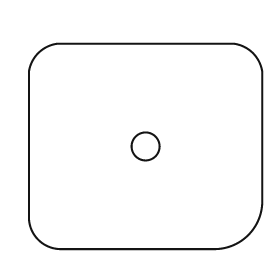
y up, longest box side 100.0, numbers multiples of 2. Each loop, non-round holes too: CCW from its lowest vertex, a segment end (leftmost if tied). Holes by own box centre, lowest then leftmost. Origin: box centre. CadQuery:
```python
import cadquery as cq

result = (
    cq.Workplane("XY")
    .moveTo(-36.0, -44.0)
    .lineTo(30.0, -44.0)
    .threePointArc((44.0, -38.0), (50.0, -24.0))
    .lineTo(50.0, 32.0)
    .threePointArc((46.0, 40.0), (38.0, 44.0))
    .lineTo(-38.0, 44.0)
    .threePointArc((-46.0, 40.0), (-50.0, 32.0))
    .lineTo(-50.0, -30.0)
    .threePointArc((-46.0, -40.0), (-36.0, -44.0))
    .close()
    .moveTo(0.0, 0.0)
    .circle(6.0)
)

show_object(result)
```